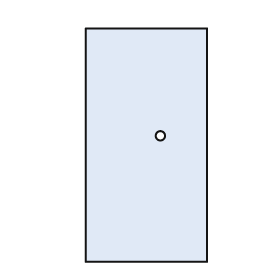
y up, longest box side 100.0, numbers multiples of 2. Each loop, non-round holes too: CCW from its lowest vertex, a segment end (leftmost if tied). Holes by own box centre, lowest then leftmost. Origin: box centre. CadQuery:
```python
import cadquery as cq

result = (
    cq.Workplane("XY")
    .moveTo(-26.0, -50.0)
    .lineTo(26.0, -50.0)
    .lineTo(26.0, 50.0)
    .lineTo(-26.0, 50.0)
    .close()
    .moveTo(6.0, 4.0)
    .circle(2.0)
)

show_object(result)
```